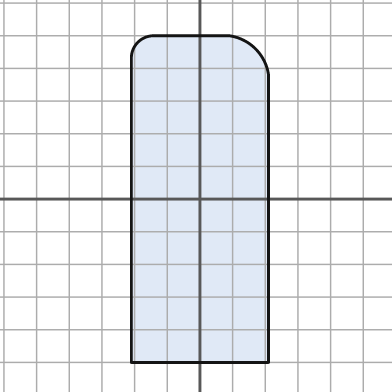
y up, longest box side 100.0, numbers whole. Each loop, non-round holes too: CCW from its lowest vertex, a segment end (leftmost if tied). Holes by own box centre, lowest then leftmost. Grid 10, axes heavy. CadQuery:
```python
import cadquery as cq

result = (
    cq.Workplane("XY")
    .moveTo(-21.0, -50.0)
    .lineTo(21.0, -50.0)
    .lineTo(21.0, 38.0)
    .threePointArc((17.0, 46.0), (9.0, 50.0))
    .lineTo(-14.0, 50.0)
    .threePointArc((-19.0, 48.0), (-21.0, 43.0))
    .close()
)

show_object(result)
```